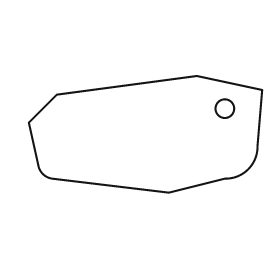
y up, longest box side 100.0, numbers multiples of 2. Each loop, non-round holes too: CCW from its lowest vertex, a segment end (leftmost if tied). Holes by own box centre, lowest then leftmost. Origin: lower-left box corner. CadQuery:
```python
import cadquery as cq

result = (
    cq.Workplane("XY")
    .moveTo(60.0, 0.0)
    .lineTo(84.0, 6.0)
    .threePointArc((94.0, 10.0), (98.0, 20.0))
    .lineTo(100.0, 44.0)
    .lineTo(72.0, 50.0)
    .lineTo(12.0, 42.0)
    .lineTo(0.0, 30.0)
    .lineTo(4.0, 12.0)
    .threePointArc((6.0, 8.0), (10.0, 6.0))
    .close()
    .moveTo(84.0, 36.0)
    .circle(4.0)
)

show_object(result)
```